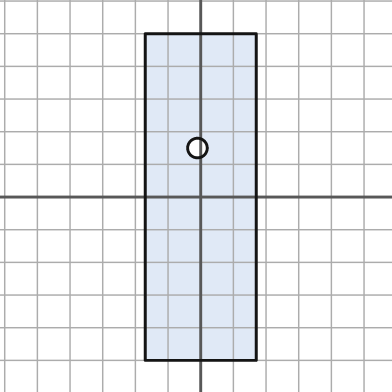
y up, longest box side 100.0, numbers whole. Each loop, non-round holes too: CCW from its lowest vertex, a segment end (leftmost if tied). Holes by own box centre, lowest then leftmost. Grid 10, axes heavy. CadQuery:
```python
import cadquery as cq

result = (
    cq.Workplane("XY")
    .moveTo(-17.0, -50.0)
    .lineTo(17.0, -50.0)
    .lineTo(17.0, 50.0)
    .lineTo(-17.0, 50.0)
    .close()
    .moveTo(-1.0, 15.0)
    .circle(3.0)
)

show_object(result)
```